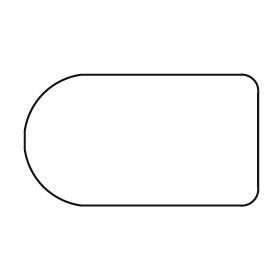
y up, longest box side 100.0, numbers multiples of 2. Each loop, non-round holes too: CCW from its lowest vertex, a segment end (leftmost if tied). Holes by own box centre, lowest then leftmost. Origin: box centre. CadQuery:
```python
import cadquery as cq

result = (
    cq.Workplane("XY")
    .moveTo(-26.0, -28.0)
    .lineTo(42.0, -28.0)
    .threePointArc((48.0, -26.0), (50.0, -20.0))
    .lineTo(50.0, 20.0)
    .threePointArc((48.0, 26.0), (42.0, 28.0))
    .lineTo(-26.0, 28.0)
    .threePointArc((-42.0, 20.0), (-50.0, 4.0))
    .lineTo(-50.0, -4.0)
    .threePointArc((-42.0, -20.0), (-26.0, -28.0))
    .close()
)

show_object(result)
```